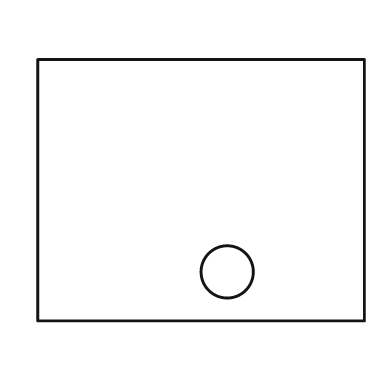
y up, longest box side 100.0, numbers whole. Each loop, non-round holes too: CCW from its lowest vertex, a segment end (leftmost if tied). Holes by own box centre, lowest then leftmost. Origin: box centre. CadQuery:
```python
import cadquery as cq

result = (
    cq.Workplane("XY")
    .moveTo(-50.0, -40.0)
    .lineTo(50.0, -40.0)
    .lineTo(50.0, 40.0)
    .lineTo(-50.0, 40.0)
    .close()
    .moveTo(8.0, -25.0)
    .circle(8.0)
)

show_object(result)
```